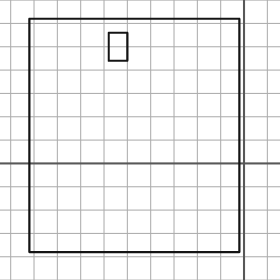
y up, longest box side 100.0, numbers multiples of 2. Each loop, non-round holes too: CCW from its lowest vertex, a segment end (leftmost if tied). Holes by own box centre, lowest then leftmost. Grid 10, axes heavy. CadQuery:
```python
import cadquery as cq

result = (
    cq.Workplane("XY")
    .moveTo(-92.0, -38.0)
    .lineTo(-2.0, -38.0)
    .lineTo(-2.0, 62.0)
    .lineTo(-92.0, 62.0)
    .close()
    .moveTo(-58.0, 44.0)
    .lineTo(-50.0, 44.0)
    .lineTo(-50.0, 56.0)
    .lineTo(-58.0, 56.0)
    .close()
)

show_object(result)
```